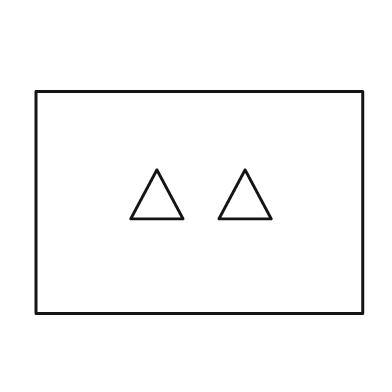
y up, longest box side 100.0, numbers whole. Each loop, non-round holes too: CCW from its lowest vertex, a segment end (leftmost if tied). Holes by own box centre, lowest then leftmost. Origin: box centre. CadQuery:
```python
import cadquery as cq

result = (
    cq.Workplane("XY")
    .moveTo(-50.0, -34.0)
    .lineTo(50.0, -34.0)
    .lineTo(50.0, 34.0)
    .lineTo(-50.0, 34.0)
    .close()
    .moveTo(-21.0, -5.0)
    .lineTo(-5.0, -5.0)
    .lineTo(-13.0, 10.0)
    .close()
    .moveTo(6.0, -5.0)
    .lineTo(22.0, -5.0)
    .lineTo(14.0, 10.0)
    .close()
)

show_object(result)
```